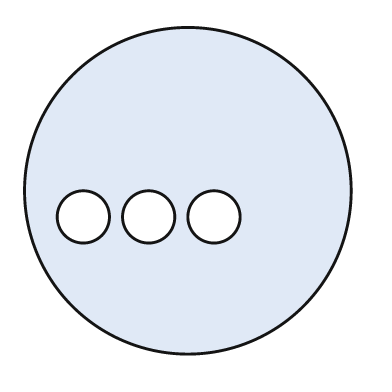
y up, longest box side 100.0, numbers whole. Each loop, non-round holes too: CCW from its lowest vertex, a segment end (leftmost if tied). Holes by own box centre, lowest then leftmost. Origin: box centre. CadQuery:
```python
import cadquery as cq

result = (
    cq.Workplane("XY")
    .moveTo(0.0, 0.0)
    .circle(50.0)
    .moveTo(-32.0, -8.0)
    .circle(8.0)
    .moveTo(-12.0, -8.0)
    .circle(8.0)
    .moveTo(8.0, -8.0)
    .circle(8.0)
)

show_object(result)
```